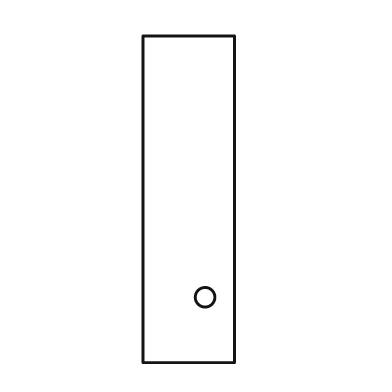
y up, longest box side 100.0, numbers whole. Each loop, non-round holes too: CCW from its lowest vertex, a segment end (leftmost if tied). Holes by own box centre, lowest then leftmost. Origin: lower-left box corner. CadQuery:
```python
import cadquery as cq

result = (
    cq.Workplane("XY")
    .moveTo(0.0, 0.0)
    .lineTo(28.0, 0.0)
    .lineTo(28.0, 100.0)
    .lineTo(0.0, 100.0)
    .close()
    .moveTo(19.0, 20.0)
    .circle(3.0)
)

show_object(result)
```